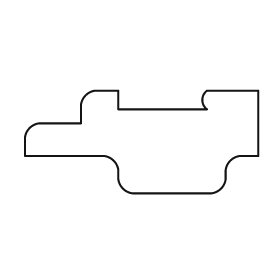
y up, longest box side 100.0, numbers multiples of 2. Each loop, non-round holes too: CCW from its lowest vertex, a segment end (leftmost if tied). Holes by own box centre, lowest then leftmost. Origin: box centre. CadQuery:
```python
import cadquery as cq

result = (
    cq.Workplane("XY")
    .moveTo(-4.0, -22.0)
    .lineTo(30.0, -22.0)
    .threePointArc((34.0, -20.0), (36.0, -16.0))
    .lineTo(36.0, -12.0)
    .threePointArc((38.0, -8.0), (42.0, -6.0))
    .lineTo(50.0, -6.0)
    .lineTo(50.0, 22.0)
    .lineTo(28.0, 22.0)
    .threePointArc((26.0, 18.0), (28.0, 14.0))
    .lineTo(-10.0, 14.0)
    .lineTo(-10.0, 22.0)
    .lineTo(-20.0, 22.0)
    .threePointArc((-24.0, 20.0), (-26.0, 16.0))
    .lineTo(-26.0, 8.0)
    .lineTo(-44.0, 8.0)
    .threePointArc((-48.0, 6.0), (-50.0, 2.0))
    .lineTo(-50.0, -6.0)
    .lineTo(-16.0, -6.0)
    .threePointArc((-12.0, -8.0), (-10.0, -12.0))
    .lineTo(-10.0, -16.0)
    .threePointArc((-8.0, -20.0), (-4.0, -22.0))
    .close()
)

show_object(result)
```